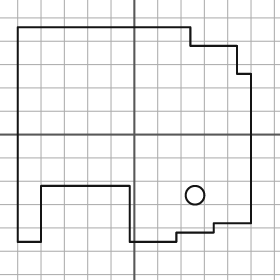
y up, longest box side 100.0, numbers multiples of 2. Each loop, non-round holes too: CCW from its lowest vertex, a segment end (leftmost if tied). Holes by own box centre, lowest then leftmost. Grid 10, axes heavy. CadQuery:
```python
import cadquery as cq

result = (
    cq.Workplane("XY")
    .moveTo(-50.0, -46.0)
    .lineTo(-40.0, -46.0)
    .lineTo(-40.0, -22.0)
    .lineTo(-2.0, -22.0)
    .lineTo(-2.0, -46.0)
    .lineTo(18.0, -46.0)
    .lineTo(18.0, -42.0)
    .lineTo(34.0, -42.0)
    .lineTo(34.0, -38.0)
    .lineTo(50.0, -38.0)
    .lineTo(50.0, 26.0)
    .lineTo(44.0, 26.0)
    .lineTo(44.0, 38.0)
    .lineTo(24.0, 38.0)
    .lineTo(24.0, 46.0)
    .lineTo(-50.0, 46.0)
    .close()
    .moveTo(26.0, -26.0)
    .circle(4.0)
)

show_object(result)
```